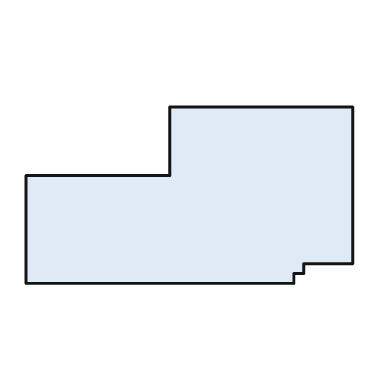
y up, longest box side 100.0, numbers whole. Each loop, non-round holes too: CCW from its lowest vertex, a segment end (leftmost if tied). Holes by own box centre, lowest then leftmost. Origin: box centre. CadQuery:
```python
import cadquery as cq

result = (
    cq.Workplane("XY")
    .moveTo(-50.0, -27.0)
    .lineTo(32.0, -27.0)
    .lineTo(32.0, -24.0)
    .lineTo(35.0, -24.0)
    .lineTo(35.0, -21.0)
    .lineTo(50.0, -21.0)
    .lineTo(50.0, 27.0)
    .lineTo(-6.0, 27.0)
    .lineTo(-6.0, 6.0)
    .lineTo(-50.0, 6.0)
    .close()
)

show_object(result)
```